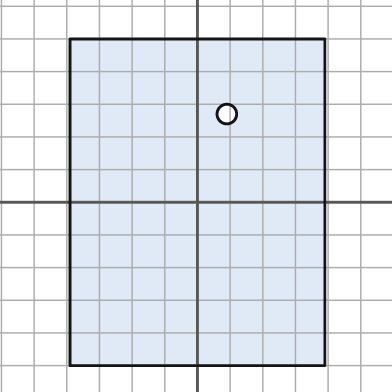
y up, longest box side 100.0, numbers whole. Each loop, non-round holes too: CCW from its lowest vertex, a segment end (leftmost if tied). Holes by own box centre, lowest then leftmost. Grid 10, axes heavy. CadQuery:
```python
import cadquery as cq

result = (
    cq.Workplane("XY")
    .moveTo(-39.0, -50.0)
    .lineTo(39.0, -50.0)
    .lineTo(39.0, 50.0)
    .lineTo(-39.0, 50.0)
    .close()
    .moveTo(9.0, 27.0)
    .circle(3.0)
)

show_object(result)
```